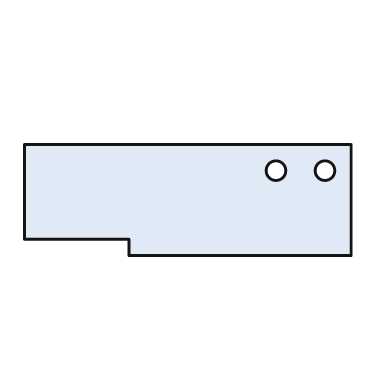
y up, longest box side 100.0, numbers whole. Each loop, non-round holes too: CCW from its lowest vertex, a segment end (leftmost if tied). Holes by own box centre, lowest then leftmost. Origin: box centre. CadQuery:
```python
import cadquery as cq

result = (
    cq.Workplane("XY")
    .moveTo(-18.0, -17.0)
    .lineTo(50.0, -17.0)
    .lineTo(50.0, 17.0)
    .lineTo(-50.0, 17.0)
    .lineTo(-50.0, -12.0)
    .lineTo(-18.0, -12.0)
    .close()
    .moveTo(27.0, 9.0)
    .circle(3.0)
    .moveTo(42.0, 9.0)
    .circle(3.0)
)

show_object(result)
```